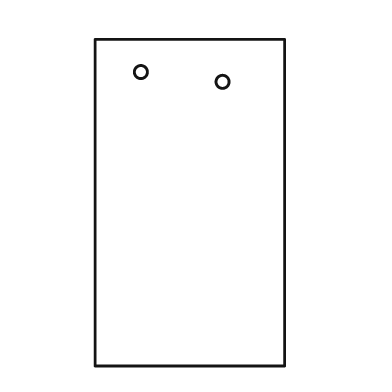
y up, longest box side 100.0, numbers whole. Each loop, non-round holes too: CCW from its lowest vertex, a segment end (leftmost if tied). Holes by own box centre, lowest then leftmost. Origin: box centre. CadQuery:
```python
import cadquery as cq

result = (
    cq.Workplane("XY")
    .moveTo(-29.0, -50.0)
    .lineTo(29.0, -50.0)
    .lineTo(29.0, 50.0)
    .lineTo(-29.0, 50.0)
    .close()
    .moveTo(10.0, 37.0)
    .circle(2.0)
    .moveTo(-15.0, 40.0)
    .circle(2.0)
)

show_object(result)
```